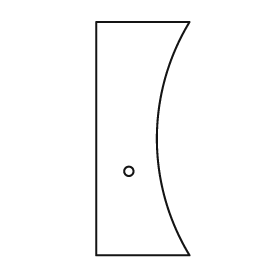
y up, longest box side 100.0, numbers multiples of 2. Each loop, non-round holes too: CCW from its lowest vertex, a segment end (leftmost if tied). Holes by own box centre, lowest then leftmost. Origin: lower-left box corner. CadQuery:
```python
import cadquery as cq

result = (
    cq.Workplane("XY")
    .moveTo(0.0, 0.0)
    .lineTo(40.0, 0.0)
    .threePointArc((26.0, 50.0), (40.0, 100.0))
    .lineTo(0.0, 100.0)
    .close()
    .moveTo(14.0, 36.0)
    .circle(2.0)
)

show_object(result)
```